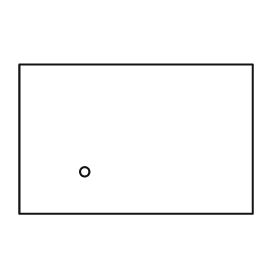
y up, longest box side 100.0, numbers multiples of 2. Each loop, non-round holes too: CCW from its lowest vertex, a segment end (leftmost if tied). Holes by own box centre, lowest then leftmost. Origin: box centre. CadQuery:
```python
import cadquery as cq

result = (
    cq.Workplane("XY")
    .moveTo(-50.0, -32.0)
    .lineTo(50.0, -32.0)
    .lineTo(50.0, 32.0)
    .lineTo(-50.0, 32.0)
    .close()
    .moveTo(-22.0, -14.0)
    .circle(2.0)
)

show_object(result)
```